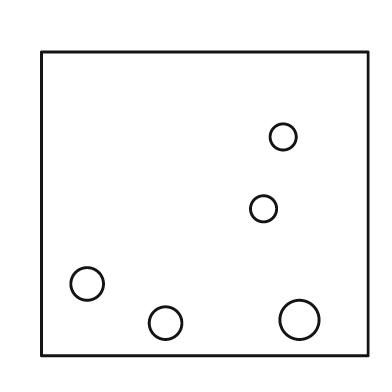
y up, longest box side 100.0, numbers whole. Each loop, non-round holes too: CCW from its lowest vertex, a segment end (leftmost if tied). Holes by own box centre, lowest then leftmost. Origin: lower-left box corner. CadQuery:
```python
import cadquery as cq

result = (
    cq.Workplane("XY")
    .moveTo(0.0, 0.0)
    .lineTo(100.0, 0.0)
    .lineTo(100.0, 93.0)
    .lineTo(0.0, 93.0)
    .close()
    .moveTo(38.0, 10.0)
    .circle(5.0)
    .moveTo(79.0, 11.0)
    .circle(6.0)
    .moveTo(14.0, 22.0)
    .circle(5.0)
    .moveTo(68.0, 45.0)
    .circle(4.0)
    .moveTo(74.0, 67.0)
    .circle(4.0)
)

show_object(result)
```